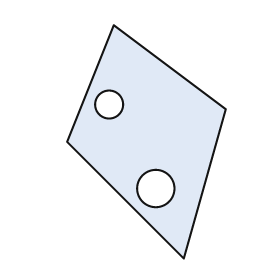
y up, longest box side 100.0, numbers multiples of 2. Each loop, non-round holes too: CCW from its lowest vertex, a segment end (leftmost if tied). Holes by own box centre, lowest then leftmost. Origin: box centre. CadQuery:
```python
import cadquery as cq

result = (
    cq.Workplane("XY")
    .moveTo(16.0, -50.0)
    .lineTo(34.0, 14.0)
    .lineTo(-14.0, 50.0)
    .lineTo(-34.0, 0.0)
    .close()
    .moveTo(4.0, -20.0)
    .circle(8.0)
    .moveTo(-16.0, 16.0)
    .circle(6.0)
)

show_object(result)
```